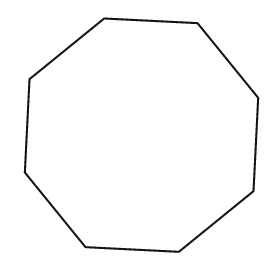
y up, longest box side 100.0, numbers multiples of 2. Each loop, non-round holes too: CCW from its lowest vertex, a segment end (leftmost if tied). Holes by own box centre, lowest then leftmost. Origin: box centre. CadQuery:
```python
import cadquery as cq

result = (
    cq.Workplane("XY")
    .moveTo(16.0, -50.0)
    .lineTo(48.0, -24.0)
    .lineTo(50.0, 16.0)
    .lineTo(24.0, 48.0)
    .lineTo(-16.0, 50.0)
    .lineTo(-48.0, 24.0)
    .lineTo(-50.0, -16.0)
    .lineTo(-24.0, -48.0)
    .close()
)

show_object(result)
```